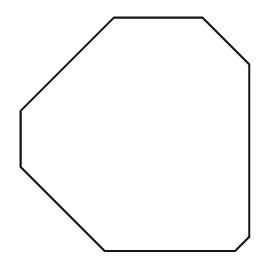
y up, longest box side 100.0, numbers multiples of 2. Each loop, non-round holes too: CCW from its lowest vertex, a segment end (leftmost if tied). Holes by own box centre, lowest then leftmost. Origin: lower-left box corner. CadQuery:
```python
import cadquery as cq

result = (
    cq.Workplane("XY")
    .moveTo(36.0, 0.0)
    .lineTo(92.0, 0.0)
    .lineTo(98.0, 6.0)
    .lineTo(98.0, 80.0)
    .lineTo(78.0, 100.0)
    .lineTo(40.0, 100.0)
    .lineTo(0.0, 60.0)
    .lineTo(0.0, 36.0)
    .close()
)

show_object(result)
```